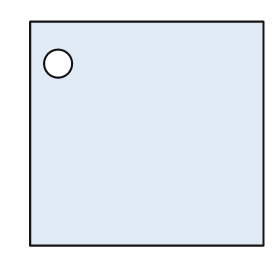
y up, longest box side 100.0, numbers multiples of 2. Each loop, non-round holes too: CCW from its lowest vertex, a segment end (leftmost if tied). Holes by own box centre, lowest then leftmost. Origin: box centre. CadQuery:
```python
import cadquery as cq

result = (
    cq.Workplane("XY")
    .moveTo(-50.0, -48.0)
    .lineTo(50.0, -48.0)
    .lineTo(50.0, 48.0)
    .lineTo(-50.0, 48.0)
    .close()
    .moveTo(-38.0, 30.0)
    .circle(6.0)
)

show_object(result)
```